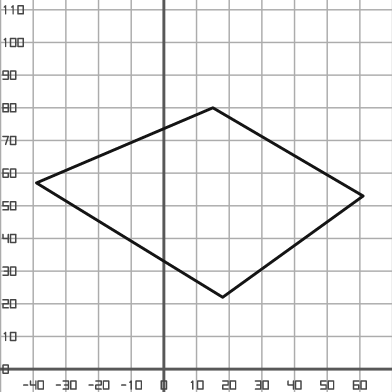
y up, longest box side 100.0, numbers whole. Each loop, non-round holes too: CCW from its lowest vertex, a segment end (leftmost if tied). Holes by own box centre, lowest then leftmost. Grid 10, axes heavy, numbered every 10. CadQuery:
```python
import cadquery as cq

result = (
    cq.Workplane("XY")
    .moveTo(18.0, 22.0)
    .lineTo(61.0, 53.0)
    .lineTo(15.0, 80.0)
    .lineTo(-39.0, 57.0)
    .close()
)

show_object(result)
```